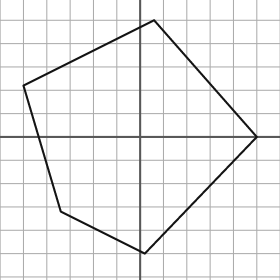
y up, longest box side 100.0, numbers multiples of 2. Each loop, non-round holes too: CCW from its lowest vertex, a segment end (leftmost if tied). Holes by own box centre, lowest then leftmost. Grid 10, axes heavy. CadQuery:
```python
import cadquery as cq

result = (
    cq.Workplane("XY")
    .moveTo(2.0, -50.0)
    .lineTo(50.0, 0.0)
    .lineTo(6.0, 50.0)
    .lineTo(-50.0, 22.0)
    .lineTo(-34.0, -32.0)
    .close()
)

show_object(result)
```